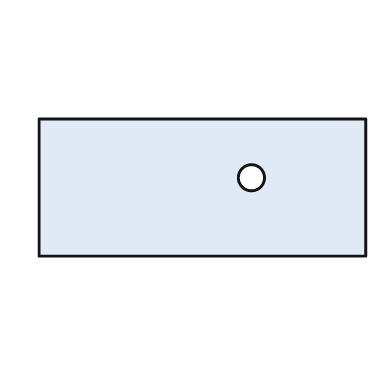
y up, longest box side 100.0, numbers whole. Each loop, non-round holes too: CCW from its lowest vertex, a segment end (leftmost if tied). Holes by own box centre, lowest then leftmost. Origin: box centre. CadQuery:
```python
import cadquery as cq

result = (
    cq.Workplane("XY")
    .moveTo(-50.0, -21.0)
    .lineTo(50.0, -21.0)
    .lineTo(50.0, 21.0)
    .lineTo(-50.0, 21.0)
    .close()
    .moveTo(15.0, 3.0)
    .circle(4.0)
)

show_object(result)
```